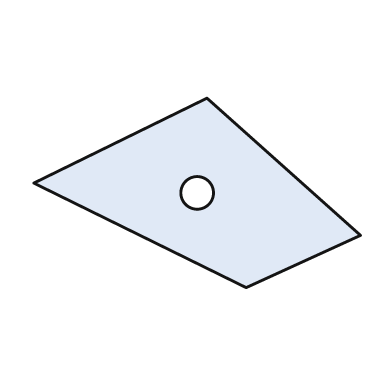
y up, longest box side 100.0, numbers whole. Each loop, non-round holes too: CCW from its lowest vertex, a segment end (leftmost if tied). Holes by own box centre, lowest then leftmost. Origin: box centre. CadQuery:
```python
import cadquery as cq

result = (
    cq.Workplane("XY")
    .moveTo(15.0, -29.0)
    .lineTo(50.0, -13.0)
    .lineTo(3.0, 29.0)
    .lineTo(-50.0, 3.0)
    .close()
    .moveTo(0.0, 0.0)
    .circle(5.0)
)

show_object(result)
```